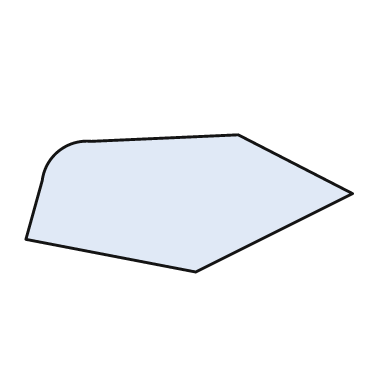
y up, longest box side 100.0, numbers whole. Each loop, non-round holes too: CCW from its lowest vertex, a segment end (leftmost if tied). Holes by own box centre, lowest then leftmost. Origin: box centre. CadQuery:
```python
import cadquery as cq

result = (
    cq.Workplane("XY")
    .moveTo(2.0, -21.0)
    .lineTo(50.0, 3.0)
    .lineTo(15.0, 21.0)
    .lineTo(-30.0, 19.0)
    .threePointArc((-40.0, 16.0), (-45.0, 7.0))
    .lineTo(-50.0, -11.0)
    .close()
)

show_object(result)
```